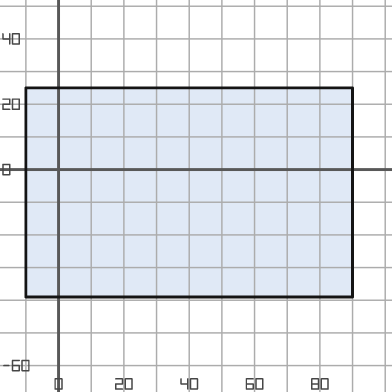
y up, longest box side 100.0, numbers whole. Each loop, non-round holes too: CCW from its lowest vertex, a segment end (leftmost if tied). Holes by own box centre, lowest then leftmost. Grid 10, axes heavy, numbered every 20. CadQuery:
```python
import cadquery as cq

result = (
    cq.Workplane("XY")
    .moveTo(-10.0, -39.0)
    .lineTo(90.0, -39.0)
    .lineTo(90.0, 25.0)
    .lineTo(-10.0, 25.0)
    .close()
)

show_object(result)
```